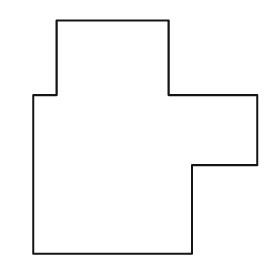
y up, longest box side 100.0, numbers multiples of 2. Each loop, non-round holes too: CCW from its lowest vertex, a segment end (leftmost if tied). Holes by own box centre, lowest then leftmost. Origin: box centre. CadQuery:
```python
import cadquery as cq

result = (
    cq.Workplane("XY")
    .moveTo(-48.0, -50.0)
    .lineTo(20.0, -50.0)
    .lineTo(20.0, -12.0)
    .lineTo(48.0, -12.0)
    .lineTo(48.0, 18.0)
    .lineTo(10.0, 18.0)
    .lineTo(10.0, 50.0)
    .lineTo(-38.0, 50.0)
    .lineTo(-38.0, 18.0)
    .lineTo(-48.0, 18.0)
    .close()
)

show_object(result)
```